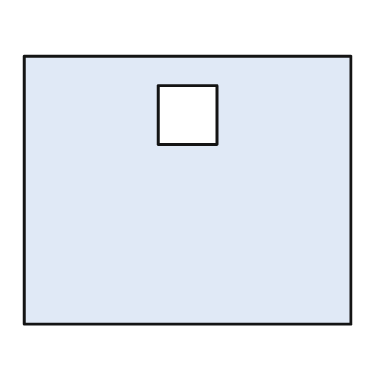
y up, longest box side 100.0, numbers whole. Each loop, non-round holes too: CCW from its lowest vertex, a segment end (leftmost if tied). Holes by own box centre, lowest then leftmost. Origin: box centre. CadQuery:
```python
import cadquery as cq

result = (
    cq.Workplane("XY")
    .moveTo(-50.0, -41.0)
    .lineTo(50.0, -41.0)
    .lineTo(50.0, 41.0)
    .lineTo(-50.0, 41.0)
    .close()
    .moveTo(-9.0, 14.0)
    .lineTo(9.0, 14.0)
    .lineTo(9.0, 32.0)
    .lineTo(-9.0, 32.0)
    .close()
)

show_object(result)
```